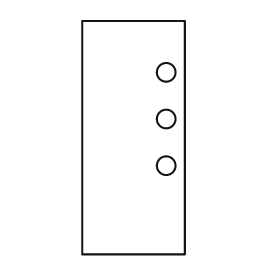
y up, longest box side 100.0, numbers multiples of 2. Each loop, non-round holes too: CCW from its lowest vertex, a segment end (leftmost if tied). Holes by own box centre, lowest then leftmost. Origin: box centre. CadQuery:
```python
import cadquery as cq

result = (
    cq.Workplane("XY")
    .moveTo(-22.0, -50.0)
    .lineTo(22.0, -50.0)
    .lineTo(22.0, 50.0)
    .lineTo(-22.0, 50.0)
    .close()
    .moveTo(14.0, -12.0)
    .circle(4.0)
    .moveTo(14.0, 8.0)
    .circle(4.0)
    .moveTo(14.0, 28.0)
    .circle(4.0)
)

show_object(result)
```